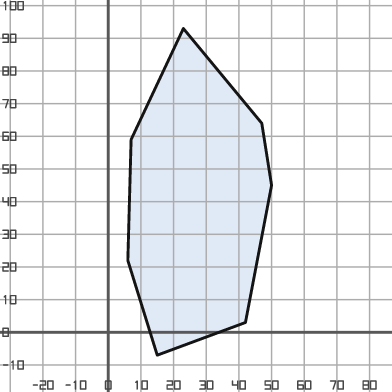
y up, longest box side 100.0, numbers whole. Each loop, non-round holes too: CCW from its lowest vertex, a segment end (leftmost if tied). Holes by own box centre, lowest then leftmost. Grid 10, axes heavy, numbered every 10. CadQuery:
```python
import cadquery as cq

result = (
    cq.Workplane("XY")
    .moveTo(15.0, -7.0)
    .lineTo(42.0, 3.0)
    .lineTo(50.0, 45.0)
    .lineTo(47.0, 64.0)
    .lineTo(23.0, 93.0)
    .lineTo(7.0, 59.0)
    .lineTo(6.0, 22.0)
    .close()
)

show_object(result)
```